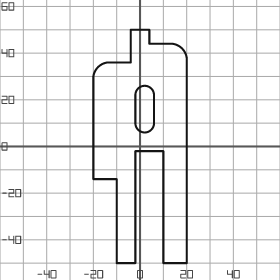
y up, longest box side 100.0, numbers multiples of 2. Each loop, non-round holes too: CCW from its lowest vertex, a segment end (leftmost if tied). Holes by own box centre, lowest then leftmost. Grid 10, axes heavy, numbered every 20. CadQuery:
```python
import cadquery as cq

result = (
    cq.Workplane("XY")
    .moveTo(-10.0, -50.0)
    .lineTo(-2.0, -50.0)
    .lineTo(-2.0, -2.0)
    .lineTo(10.0, -2.0)
    .lineTo(10.0, -50.0)
    .lineTo(20.0, -50.0)
    .lineTo(20.0, 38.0)
    .threePointArc((18.0, 42.0), (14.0, 44.0))
    .lineTo(4.0, 44.0)
    .lineTo(4.0, 50.0)
    .lineTo(-4.0, 50.0)
    .lineTo(-4.0, 36.0)
    .lineTo(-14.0, 36.0)
    .threePointArc((-18.0, 34.0), (-20.0, 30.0))
    .lineTo(-20.0, -14.0)
    .lineTo(-10.0, -14.0)
    .close()
    .moveTo(-2.0, 10.0)
    .threePointArc((2.0, 6.0), (6.0, 10.0))
    .lineTo(6.0, 22.0)
    .threePointArc((2.0, 26.0), (-2.0, 22.0))
    .close()
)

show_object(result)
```